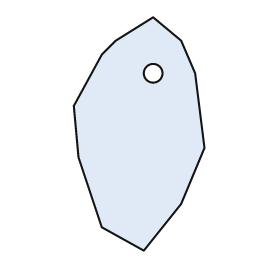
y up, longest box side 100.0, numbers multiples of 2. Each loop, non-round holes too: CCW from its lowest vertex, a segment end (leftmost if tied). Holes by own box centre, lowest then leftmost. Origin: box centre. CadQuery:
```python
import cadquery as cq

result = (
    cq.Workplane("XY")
    .moveTo(2.0, -50.0)
    .lineTo(18.0, -30.0)
    .lineTo(28.0, -6.0)
    .lineTo(24.0, 26.0)
    .lineTo(18.0, 40.0)
    .lineTo(6.0, 50.0)
    .lineTo(-10.0, 40.0)
    .lineTo(-16.0, 34.0)
    .lineTo(-28.0, 12.0)
    .lineTo(-26.0, -10.0)
    .lineTo(-16.0, -40.0)
    .close()
    .moveTo(6.0, 26.0)
    .circle(4.0)
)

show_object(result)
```